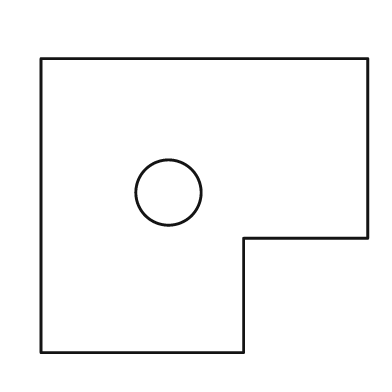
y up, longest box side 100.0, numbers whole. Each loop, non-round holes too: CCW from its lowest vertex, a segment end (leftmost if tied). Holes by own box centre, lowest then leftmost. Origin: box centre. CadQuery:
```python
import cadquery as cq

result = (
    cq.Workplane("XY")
    .moveTo(-50.0, -45.0)
    .lineTo(12.0, -45.0)
    .lineTo(12.0, -10.0)
    .lineTo(50.0, -10.0)
    .lineTo(50.0, 45.0)
    .lineTo(-50.0, 45.0)
    .close()
    .moveTo(-11.0, 4.0)
    .circle(10.0)
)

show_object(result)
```